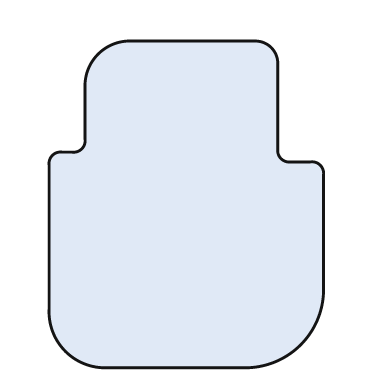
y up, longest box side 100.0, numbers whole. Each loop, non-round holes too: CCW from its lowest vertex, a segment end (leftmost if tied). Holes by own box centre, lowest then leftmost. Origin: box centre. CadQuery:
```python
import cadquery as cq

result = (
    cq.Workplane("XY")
    .moveTo(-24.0, -50.0)
    .lineTo(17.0, -50.0)
    .threePointArc((35.0, -43.0), (42.0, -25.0))
    .lineTo(42.0, 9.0)
    .threePointArc((41.0, 12.0), (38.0, 13.0))
    .lineTo(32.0, 13.0)
    .threePointArc((29.0, 14.0), (28.0, 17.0))
    .lineTo(28.0, 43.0)
    .threePointArc((26.0, 48.0), (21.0, 50.0))
    .lineTo(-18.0, 50.0)
    .threePointArc((-27.0, 46.0), (-31.0, 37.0))
    .lineTo(-31.0, 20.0)
    .threePointArc((-32.0, 17.0), (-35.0, 16.0))
    .lineTo(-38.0, 16.0)
    .threePointArc((-41.0, 15.0), (-42.0, 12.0))
    .lineTo(-42.0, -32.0)
    .threePointArc((-37.0, -45.0), (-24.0, -50.0))
    .close()
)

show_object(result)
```